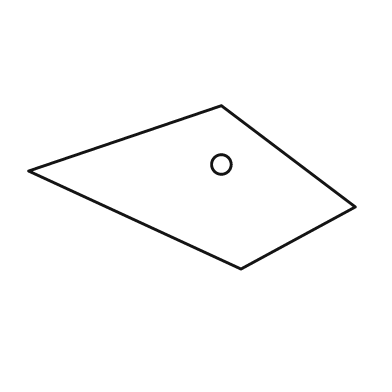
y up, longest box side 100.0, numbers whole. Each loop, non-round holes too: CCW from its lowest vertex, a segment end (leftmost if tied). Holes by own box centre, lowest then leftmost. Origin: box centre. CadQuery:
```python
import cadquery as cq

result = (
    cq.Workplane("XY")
    .moveTo(15.0, -25.0)
    .lineTo(50.0, -6.0)
    .lineTo(9.0, 25.0)
    .lineTo(-50.0, 5.0)
    .close()
    .moveTo(9.0, 7.0)
    .circle(3.0)
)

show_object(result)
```